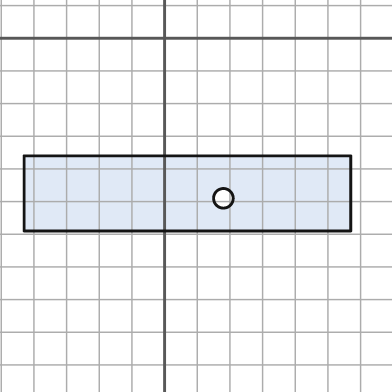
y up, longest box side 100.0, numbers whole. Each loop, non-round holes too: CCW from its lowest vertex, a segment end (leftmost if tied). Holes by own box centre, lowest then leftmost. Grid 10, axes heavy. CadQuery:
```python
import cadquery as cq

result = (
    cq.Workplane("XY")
    .moveTo(-43.0, -59.0)
    .lineTo(57.0, -59.0)
    .lineTo(57.0, -36.0)
    .lineTo(-43.0, -36.0)
    .close()
    .moveTo(18.0, -49.0)
    .circle(3.0)
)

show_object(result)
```